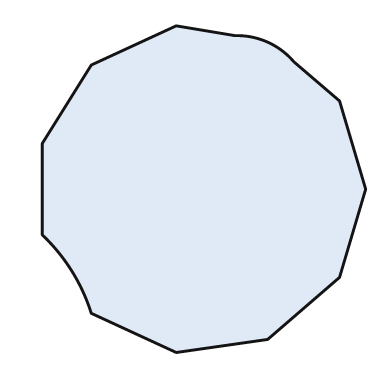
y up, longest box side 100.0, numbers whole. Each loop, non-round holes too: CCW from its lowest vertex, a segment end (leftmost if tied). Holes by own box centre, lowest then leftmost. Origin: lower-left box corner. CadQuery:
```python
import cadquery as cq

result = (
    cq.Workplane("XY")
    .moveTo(41.0, 0.0)
    .lineTo(69.0, 4.0)
    .lineTo(91.0, 23.0)
    .lineTo(99.0, 50.0)
    .lineTo(91.0, 77.0)
    .lineTo(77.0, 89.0)
    .threePointArc((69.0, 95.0), (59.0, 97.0))
    .lineTo(41.0, 100.0)
    .lineTo(15.0, 88.0)
    .lineTo(0.0, 64.0)
    .lineTo(0.0, 36.0)
    .threePointArc((9.0, 25.0), (15.0, 12.0))
    .close()
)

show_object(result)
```